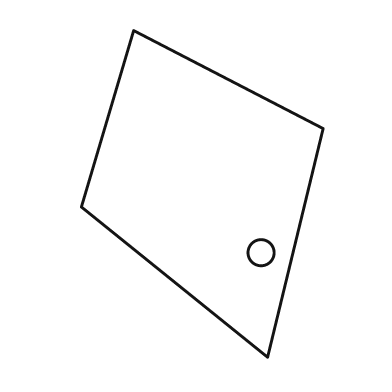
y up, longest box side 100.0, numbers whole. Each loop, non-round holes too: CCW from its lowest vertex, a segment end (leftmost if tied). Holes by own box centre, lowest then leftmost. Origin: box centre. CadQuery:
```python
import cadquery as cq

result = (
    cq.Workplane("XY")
    .moveTo(20.0, -50.0)
    .lineTo(37.0, 20.0)
    .lineTo(-21.0, 50.0)
    .lineTo(-37.0, -4.0)
    .close()
    .moveTo(18.0, -18.0)
    .circle(4.0)
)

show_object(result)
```